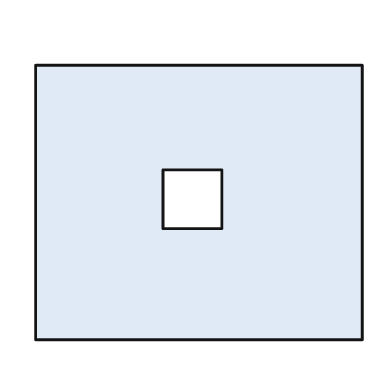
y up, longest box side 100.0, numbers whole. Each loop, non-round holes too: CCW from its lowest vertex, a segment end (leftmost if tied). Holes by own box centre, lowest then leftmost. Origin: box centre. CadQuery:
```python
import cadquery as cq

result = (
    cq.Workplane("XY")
    .moveTo(-50.0, -42.0)
    .lineTo(50.0, -42.0)
    .lineTo(50.0, 42.0)
    .lineTo(-50.0, 42.0)
    .close()
    .moveTo(-11.0, -8.0)
    .lineTo(7.0, -8.0)
    .lineTo(7.0, 10.0)
    .lineTo(-11.0, 10.0)
    .close()
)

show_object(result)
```